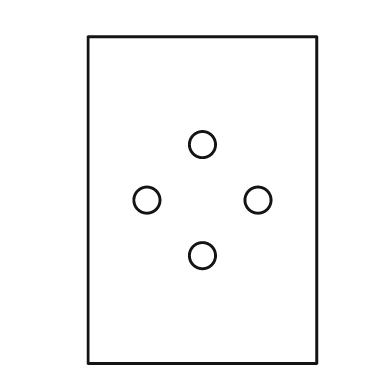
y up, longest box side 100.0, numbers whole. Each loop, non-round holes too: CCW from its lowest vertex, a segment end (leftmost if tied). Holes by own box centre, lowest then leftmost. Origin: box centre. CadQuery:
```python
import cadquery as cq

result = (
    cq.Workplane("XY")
    .moveTo(-35.0, -50.0)
    .lineTo(35.0, -50.0)
    .lineTo(35.0, 50.0)
    .lineTo(-35.0, 50.0)
    .close()
    .moveTo(0.0, -17.0)
    .circle(4.0)
    .moveTo(-17.0, 0.0)
    .circle(4.0)
    .moveTo(17.0, 0.0)
    .circle(4.0)
    .moveTo(0.0, 17.0)
    .circle(4.0)
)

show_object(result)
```